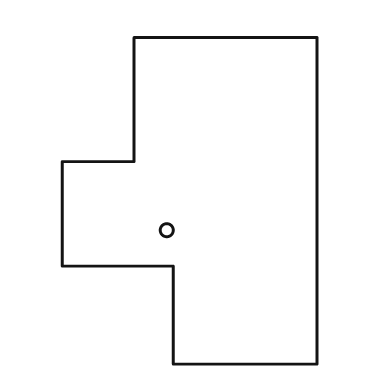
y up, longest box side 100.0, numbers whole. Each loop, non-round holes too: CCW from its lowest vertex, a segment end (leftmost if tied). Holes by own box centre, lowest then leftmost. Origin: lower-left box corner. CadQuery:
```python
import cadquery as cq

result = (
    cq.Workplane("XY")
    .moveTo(34.0, 0.0)
    .lineTo(78.0, 0.0)
    .lineTo(78.0, 100.0)
    .lineTo(22.0, 100.0)
    .lineTo(22.0, 62.0)
    .lineTo(0.0, 62.0)
    .lineTo(0.0, 30.0)
    .lineTo(34.0, 30.0)
    .close()
    .moveTo(32.0, 41.0)
    .circle(2.0)
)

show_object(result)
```